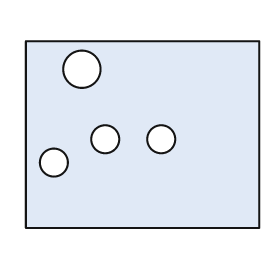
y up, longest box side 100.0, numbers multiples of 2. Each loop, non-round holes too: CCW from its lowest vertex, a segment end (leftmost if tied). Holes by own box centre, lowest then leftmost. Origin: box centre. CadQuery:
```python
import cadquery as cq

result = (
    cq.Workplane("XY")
    .moveTo(-50.0, -40.0)
    .lineTo(50.0, -40.0)
    .lineTo(50.0, 40.0)
    .lineTo(-50.0, 40.0)
    .close()
    .moveTo(-38.0, -12.0)
    .circle(6.0)
    .moveTo(-16.0, -2.0)
    .circle(6.0)
    .moveTo(8.0, -2.0)
    .circle(6.0)
    .moveTo(-26.0, 28.0)
    .circle(8.0)
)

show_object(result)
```